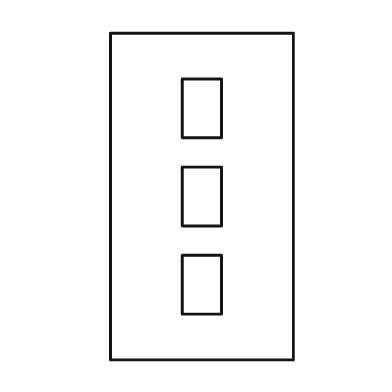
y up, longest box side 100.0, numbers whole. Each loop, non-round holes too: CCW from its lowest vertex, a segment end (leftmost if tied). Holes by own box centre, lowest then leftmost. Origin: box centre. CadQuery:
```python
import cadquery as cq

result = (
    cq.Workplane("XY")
    .moveTo(-28.0, -50.0)
    .lineTo(28.0, -50.0)
    .lineTo(28.0, 50.0)
    .lineTo(-28.0, 50.0)
    .close()
    .moveTo(-6.0, -36.0)
    .lineTo(6.0, -36.0)
    .lineTo(6.0, -18.0)
    .lineTo(-6.0, -18.0)
    .close()
    .moveTo(-6.0, -9.0)
    .lineTo(6.0, -9.0)
    .lineTo(6.0, 9.0)
    .lineTo(-6.0, 9.0)
    .close()
    .moveTo(-6.0, 18.0)
    .lineTo(6.0, 18.0)
    .lineTo(6.0, 36.0)
    .lineTo(-6.0, 36.0)
    .close()
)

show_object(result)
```